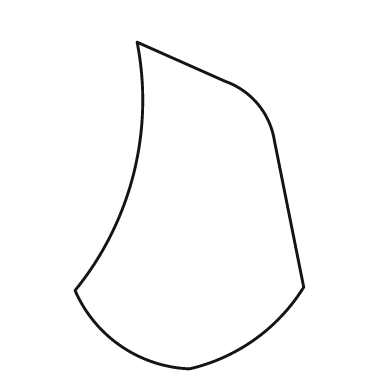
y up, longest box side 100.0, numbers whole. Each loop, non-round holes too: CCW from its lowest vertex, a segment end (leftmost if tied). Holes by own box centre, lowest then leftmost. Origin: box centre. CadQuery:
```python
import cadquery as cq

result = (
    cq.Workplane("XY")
    .moveTo(0.0, -50.0)
    .threePointArc((20.0, -41.0), (35.0, -25.0))
    .lineTo(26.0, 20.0)
    .threePointArc((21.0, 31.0), (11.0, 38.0))
    .lineTo(-16.0, 50.0)
    .threePointArc((-17.0, 10.0), (-35.0, -26.0))
    .threePointArc((-21.0, -43.0), (0.0, -50.0))
    .close()
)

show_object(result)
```